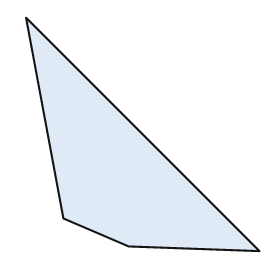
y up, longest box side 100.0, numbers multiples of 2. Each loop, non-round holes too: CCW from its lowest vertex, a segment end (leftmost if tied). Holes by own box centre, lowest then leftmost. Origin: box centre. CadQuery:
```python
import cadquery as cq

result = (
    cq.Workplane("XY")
    .moveTo(50.0, -50.0)
    .lineTo(-50.0, 50.0)
    .lineTo(-34.0, -36.0)
    .lineTo(-6.0, -48.0)
    .close()
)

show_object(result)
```